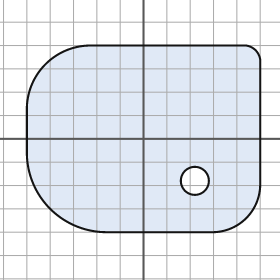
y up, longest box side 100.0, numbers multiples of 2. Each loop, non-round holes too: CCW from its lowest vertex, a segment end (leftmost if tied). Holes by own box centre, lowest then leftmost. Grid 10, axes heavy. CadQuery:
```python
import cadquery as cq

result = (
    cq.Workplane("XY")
    .moveTo(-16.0, -40.0)
    .lineTo(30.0, -40.0)
    .threePointArc((44.0, -34.0), (50.0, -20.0))
    .lineTo(50.0, 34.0)
    .threePointArc((48.0, 38.0), (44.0, 40.0))
    .lineTo(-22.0, 40.0)
    .threePointArc((-42.0, 32.0), (-50.0, 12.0))
    .lineTo(-50.0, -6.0)
    .threePointArc((-40.0, -30.0), (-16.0, -40.0))
    .close()
    .moveTo(22.0, -18.0)
    .circle(6.0)
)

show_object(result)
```